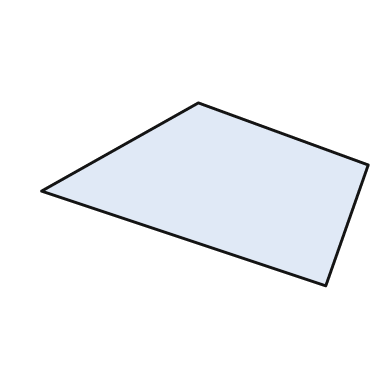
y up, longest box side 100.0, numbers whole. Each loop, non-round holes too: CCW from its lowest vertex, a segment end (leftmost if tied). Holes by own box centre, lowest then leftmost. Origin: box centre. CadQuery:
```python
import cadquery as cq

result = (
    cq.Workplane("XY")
    .moveTo(37.0, -28.0)
    .lineTo(50.0, 9.0)
    .lineTo(-2.0, 28.0)
    .lineTo(-50.0, 1.0)
    .close()
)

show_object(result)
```